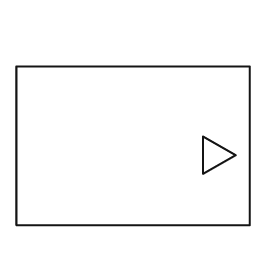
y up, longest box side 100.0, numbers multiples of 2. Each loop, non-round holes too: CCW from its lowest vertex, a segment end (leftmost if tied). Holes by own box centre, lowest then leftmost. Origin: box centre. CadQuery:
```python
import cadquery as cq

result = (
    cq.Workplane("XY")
    .moveTo(-50.0, -34.0)
    .lineTo(50.0, -34.0)
    .lineTo(50.0, 34.0)
    .lineTo(-50.0, 34.0)
    .close()
    .moveTo(30.0, -12.0)
    .lineTo(44.0, -4.0)
    .lineTo(30.0, 4.0)
    .close()
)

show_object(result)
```